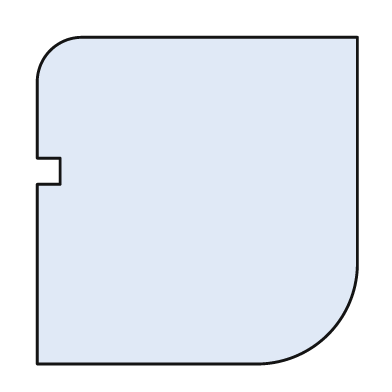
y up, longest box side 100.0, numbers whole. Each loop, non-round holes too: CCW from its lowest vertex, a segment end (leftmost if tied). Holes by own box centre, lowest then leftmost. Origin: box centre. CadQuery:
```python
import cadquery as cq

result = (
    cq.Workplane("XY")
    .moveTo(-49.0, -50.0)
    .lineTo(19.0, -50.0)
    .threePointArc((40.0, -41.0), (49.0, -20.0))
    .lineTo(49.0, 50.0)
    .lineTo(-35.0, 50.0)
    .threePointArc((-45.0, 46.0), (-49.0, 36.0))
    .lineTo(-49.0, 13.0)
    .lineTo(-42.0, 13.0)
    .lineTo(-42.0, 5.0)
    .lineTo(-49.0, 5.0)
    .close()
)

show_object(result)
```